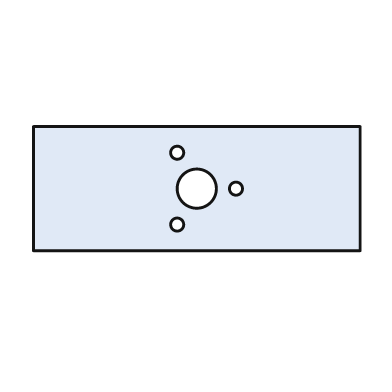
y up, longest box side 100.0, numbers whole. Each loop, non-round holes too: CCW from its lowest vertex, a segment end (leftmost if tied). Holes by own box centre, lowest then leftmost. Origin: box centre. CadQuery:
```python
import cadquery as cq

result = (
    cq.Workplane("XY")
    .moveTo(-50.0, -19.0)
    .lineTo(50.0, -19.0)
    .lineTo(50.0, 19.0)
    .lineTo(-50.0, 19.0)
    .close()
    .moveTo(-6.0, -11.0)
    .circle(2.0)
    .moveTo(0.0, 0.0)
    .circle(6.0)
    .moveTo(12.0, 0.0)
    .circle(2.0)
    .moveTo(-6.0, 11.0)
    .circle(2.0)
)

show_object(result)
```